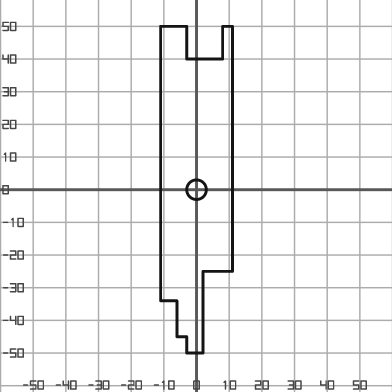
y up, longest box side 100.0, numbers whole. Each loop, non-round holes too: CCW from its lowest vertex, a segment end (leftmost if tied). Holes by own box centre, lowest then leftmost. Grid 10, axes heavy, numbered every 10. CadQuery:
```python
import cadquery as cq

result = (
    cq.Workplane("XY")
    .moveTo(-3.0, -50.0)
    .lineTo(2.0, -50.0)
    .lineTo(2.0, -25.0)
    .lineTo(11.0, -25.0)
    .lineTo(11.0, 50.0)
    .lineTo(8.0, 50.0)
    .lineTo(8.0, 40.0)
    .lineTo(-3.0, 40.0)
    .lineTo(-3.0, 50.0)
    .lineTo(-11.0, 50.0)
    .lineTo(-11.0, -34.0)
    .lineTo(-6.0, -34.0)
    .lineTo(-6.0, -45.0)
    .lineTo(-3.0, -45.0)
    .close()
    .moveTo(0.0, 0.0)
    .circle(3.0)
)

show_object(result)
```